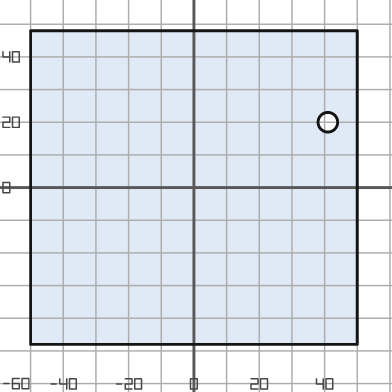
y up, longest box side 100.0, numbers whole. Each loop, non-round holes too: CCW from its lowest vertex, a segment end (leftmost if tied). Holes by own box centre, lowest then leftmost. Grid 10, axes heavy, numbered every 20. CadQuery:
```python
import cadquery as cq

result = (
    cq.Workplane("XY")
    .moveTo(-50.0, -48.0)
    .lineTo(50.0, -48.0)
    .lineTo(50.0, 48.0)
    .lineTo(-50.0, 48.0)
    .close()
    .moveTo(41.0, 20.0)
    .circle(3.0)
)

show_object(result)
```